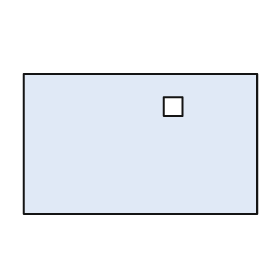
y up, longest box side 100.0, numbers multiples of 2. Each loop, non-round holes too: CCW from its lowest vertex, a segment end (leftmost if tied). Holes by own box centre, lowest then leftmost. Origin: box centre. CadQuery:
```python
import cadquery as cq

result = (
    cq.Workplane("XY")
    .moveTo(-50.0, -30.0)
    .lineTo(50.0, -30.0)
    .lineTo(50.0, 30.0)
    .lineTo(-50.0, 30.0)
    .close()
    .moveTo(10.0, 12.0)
    .lineTo(18.0, 12.0)
    .lineTo(18.0, 20.0)
    .lineTo(10.0, 20.0)
    .close()
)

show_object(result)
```